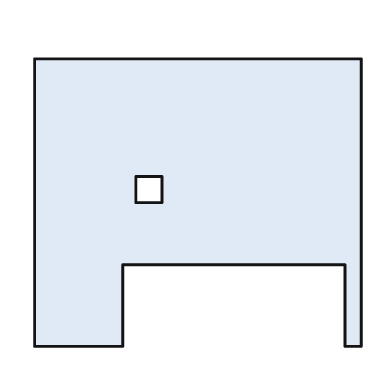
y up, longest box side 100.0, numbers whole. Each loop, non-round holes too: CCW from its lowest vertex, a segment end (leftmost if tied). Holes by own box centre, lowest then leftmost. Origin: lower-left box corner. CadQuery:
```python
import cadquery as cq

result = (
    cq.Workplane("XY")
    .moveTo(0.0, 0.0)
    .lineTo(27.0, 0.0)
    .lineTo(27.0, 25.0)
    .lineTo(95.0, 25.0)
    .lineTo(95.0, 0.0)
    .lineTo(100.0, 0.0)
    .lineTo(100.0, 88.0)
    .lineTo(0.0, 88.0)
    .close()
    .moveTo(31.0, 44.0)
    .lineTo(39.0, 44.0)
    .lineTo(39.0, 52.0)
    .lineTo(31.0, 52.0)
    .close()
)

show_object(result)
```